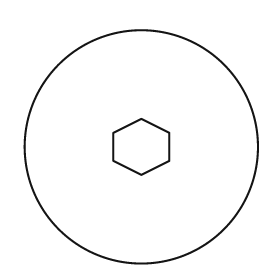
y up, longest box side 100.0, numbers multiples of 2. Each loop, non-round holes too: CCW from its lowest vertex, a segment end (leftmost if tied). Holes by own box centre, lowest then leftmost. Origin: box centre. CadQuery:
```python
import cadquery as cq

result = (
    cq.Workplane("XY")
    .moveTo(0.0, 0.0)
    .circle(50.0)
    .moveTo(0.0, -12.0)
    .lineTo(12.0, -6.0)
    .lineTo(12.0, 6.0)
    .lineTo(0.0, 12.0)
    .lineTo(-12.0, 6.0)
    .lineTo(-12.0, -6.0)
    .close()
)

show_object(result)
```